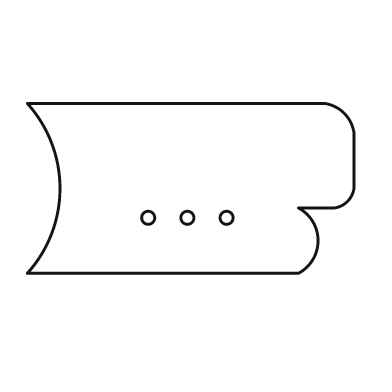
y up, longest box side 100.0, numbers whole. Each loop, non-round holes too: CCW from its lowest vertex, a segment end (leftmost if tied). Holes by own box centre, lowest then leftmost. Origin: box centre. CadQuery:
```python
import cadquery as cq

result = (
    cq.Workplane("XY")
    .moveTo(-50.0, -26.0)
    .lineTo(33.0, -26.0)
    .threePointArc((39.0, -16.0), (33.0, -6.0))
    .lineTo(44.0, -6.0)
    .threePointArc((48.0, -4.0), (50.0, 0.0))
    .lineTo(50.0, 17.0)
    .threePointArc((47.0, 23.0), (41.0, 26.0))
    .lineTo(-50.0, 26.0)
    .threePointArc((-40.0, 0.0), (-50.0, -26.0))
    .close()
    .moveTo(-13.0, -9.0)
    .circle(2.0)
    .moveTo(-1.0, -9.0)
    .circle(2.0)
    .moveTo(11.0, -9.0)
    .circle(2.0)
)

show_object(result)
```